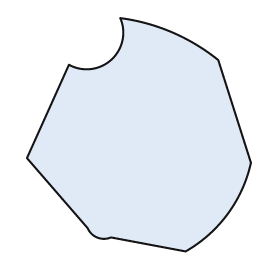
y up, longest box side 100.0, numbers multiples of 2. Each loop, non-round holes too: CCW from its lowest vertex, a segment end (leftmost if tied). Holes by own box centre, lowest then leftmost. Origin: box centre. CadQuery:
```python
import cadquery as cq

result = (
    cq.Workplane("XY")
    .moveTo(20.0, -50.0)
    .threePointArc((38.0, -34.0), (48.0, -12.0))
    .lineTo(34.0, 32.0)
    .threePointArc((14.0, 44.0), (-8.0, 50.0))
    .threePointArc((-12.0, 32.0), (-30.0, 30.0))
    .lineTo(-48.0, -10.0)
    .lineTo(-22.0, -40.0)
    .threePointArc((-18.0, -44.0), (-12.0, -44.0))
    .close()
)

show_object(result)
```